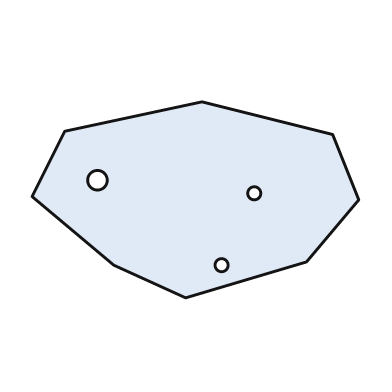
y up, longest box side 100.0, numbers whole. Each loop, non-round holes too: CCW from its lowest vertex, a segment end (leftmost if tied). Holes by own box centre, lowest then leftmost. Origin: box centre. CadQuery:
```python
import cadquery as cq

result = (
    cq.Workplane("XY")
    .moveTo(-3.0, -30.0)
    .lineTo(34.0, -19.0)
    .lineTo(50.0, 0.0)
    .lineTo(42.0, 20.0)
    .lineTo(2.0, 30.0)
    .lineTo(-40.0, 21.0)
    .lineTo(-50.0, 1.0)
    .lineTo(-25.0, -20.0)
    .close()
    .moveTo(8.0, -20.0)
    .circle(2.0)
    .moveTo(18.0, 2.0)
    .circle(2.0)
    .moveTo(-30.0, 6.0)
    .circle(3.0)
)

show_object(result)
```